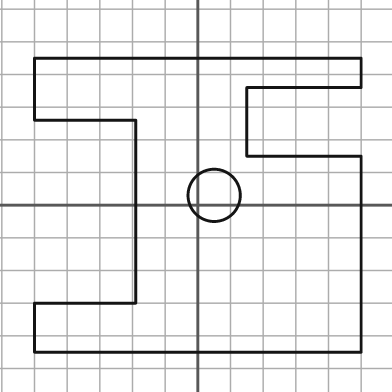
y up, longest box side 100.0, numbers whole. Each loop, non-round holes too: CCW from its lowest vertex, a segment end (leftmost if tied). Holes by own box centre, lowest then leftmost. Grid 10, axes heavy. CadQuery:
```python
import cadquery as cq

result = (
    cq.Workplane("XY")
    .moveTo(-50.0, -45.0)
    .lineTo(50.0, -45.0)
    .lineTo(50.0, 15.0)
    .lineTo(15.0, 15.0)
    .lineTo(15.0, 36.0)
    .lineTo(50.0, 36.0)
    .lineTo(50.0, 45.0)
    .lineTo(-50.0, 45.0)
    .lineTo(-50.0, 26.0)
    .lineTo(-19.0, 26.0)
    .lineTo(-19.0, -30.0)
    .lineTo(-50.0, -30.0)
    .close()
    .moveTo(5.0, 3.0)
    .circle(8.0)
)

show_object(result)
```